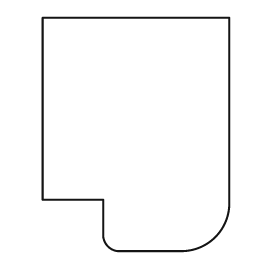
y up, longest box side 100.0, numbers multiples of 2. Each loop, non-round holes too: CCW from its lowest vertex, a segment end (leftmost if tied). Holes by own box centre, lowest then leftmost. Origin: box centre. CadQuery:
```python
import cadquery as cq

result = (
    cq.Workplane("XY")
    .moveTo(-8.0, -50.0)
    .lineTo(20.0, -50.0)
    .threePointArc((34.0, -44.0), (40.0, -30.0))
    .lineTo(40.0, 50.0)
    .lineTo(-40.0, 50.0)
    .lineTo(-40.0, -28.0)
    .lineTo(-14.0, -28.0)
    .lineTo(-14.0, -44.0)
    .threePointArc((-12.0, -48.0), (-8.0, -50.0))
    .close()
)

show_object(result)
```